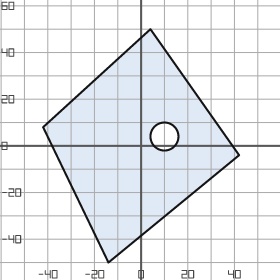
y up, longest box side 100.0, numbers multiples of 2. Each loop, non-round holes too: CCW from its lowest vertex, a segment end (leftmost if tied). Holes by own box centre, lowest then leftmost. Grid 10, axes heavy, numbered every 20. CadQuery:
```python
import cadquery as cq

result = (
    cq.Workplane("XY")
    .moveTo(-14.0, -50.0)
    .lineTo(42.0, -4.0)
    .lineTo(4.0, 50.0)
    .lineTo(-42.0, 8.0)
    .close()
    .moveTo(10.0, 4.0)
    .circle(6.0)
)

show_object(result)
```